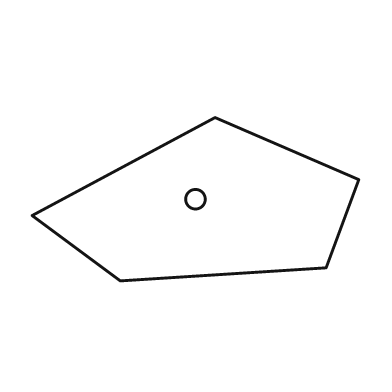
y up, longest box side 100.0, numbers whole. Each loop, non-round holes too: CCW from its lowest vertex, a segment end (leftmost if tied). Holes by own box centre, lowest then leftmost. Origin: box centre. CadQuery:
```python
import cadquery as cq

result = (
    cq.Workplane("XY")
    .moveTo(-23.0, -25.0)
    .lineTo(40.0, -21.0)
    .lineTo(50.0, 6.0)
    .lineTo(6.0, 25.0)
    .lineTo(-50.0, -5.0)
    .close()
    .moveTo(0.0, 0.0)
    .circle(3.0)
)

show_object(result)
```